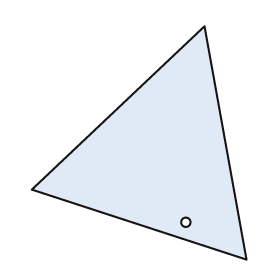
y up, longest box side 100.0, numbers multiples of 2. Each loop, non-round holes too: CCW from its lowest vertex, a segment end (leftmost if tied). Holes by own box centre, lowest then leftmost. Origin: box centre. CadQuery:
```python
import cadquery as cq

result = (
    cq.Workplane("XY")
    .moveTo(46.0, -50.0)
    .lineTo(28.0, 50.0)
    .lineTo(-46.0, -20.0)
    .close()
    .moveTo(20.0, -34.0)
    .circle(2.0)
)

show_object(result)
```